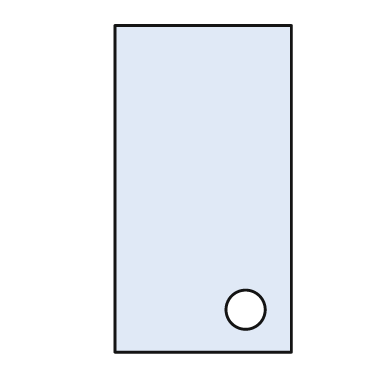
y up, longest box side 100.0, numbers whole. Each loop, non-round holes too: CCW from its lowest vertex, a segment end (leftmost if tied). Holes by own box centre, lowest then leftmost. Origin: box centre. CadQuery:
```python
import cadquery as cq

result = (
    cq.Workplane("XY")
    .moveTo(-27.0, -50.0)
    .lineTo(27.0, -50.0)
    .lineTo(27.0, 50.0)
    .lineTo(-27.0, 50.0)
    .close()
    .moveTo(13.0, -37.0)
    .circle(6.0)
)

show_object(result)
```